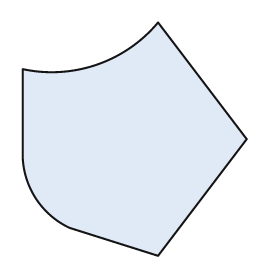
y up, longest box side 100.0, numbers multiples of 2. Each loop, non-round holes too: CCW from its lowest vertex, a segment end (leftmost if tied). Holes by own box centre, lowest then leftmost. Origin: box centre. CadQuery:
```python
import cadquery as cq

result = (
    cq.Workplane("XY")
    .moveTo(10.0, -50.0)
    .lineTo(48.0, 0.0)
    .lineTo(10.0, 50.0)
    .threePointArc((-16.0, 32.0), (-48.0, 30.0))
    .lineTo(-48.0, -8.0)
    .threePointArc((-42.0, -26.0), (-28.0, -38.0))
    .close()
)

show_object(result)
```